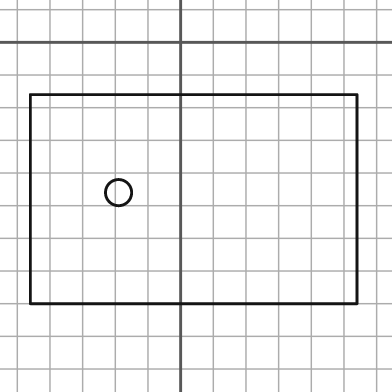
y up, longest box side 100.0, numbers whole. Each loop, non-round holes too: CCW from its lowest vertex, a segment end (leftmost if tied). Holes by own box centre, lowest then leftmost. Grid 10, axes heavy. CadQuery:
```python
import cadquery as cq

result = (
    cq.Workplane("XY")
    .moveTo(-46.0, -80.0)
    .lineTo(54.0, -80.0)
    .lineTo(54.0, -16.0)
    .lineTo(-46.0, -16.0)
    .close()
    .moveTo(-19.0, -46.0)
    .circle(4.0)
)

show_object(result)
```